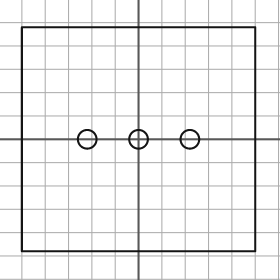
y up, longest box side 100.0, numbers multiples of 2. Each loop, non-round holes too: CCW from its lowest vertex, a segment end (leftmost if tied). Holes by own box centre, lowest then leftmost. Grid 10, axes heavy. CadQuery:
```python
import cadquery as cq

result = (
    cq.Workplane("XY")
    .moveTo(-50.0, -48.0)
    .lineTo(50.0, -48.0)
    .lineTo(50.0, 48.0)
    .lineTo(-50.0, 48.0)
    .close()
    .moveTo(-22.0, 0.0)
    .circle(4.0)
    .moveTo(0.0, 0.0)
    .circle(4.0)
    .moveTo(22.0, 0.0)
    .circle(4.0)
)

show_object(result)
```